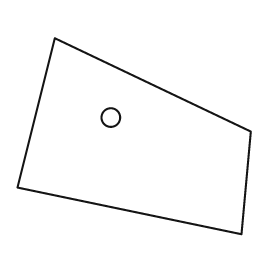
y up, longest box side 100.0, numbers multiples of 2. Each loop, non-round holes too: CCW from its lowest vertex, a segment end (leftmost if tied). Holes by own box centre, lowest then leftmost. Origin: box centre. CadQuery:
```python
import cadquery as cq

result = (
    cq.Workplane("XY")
    .moveTo(46.0, -42.0)
    .lineTo(50.0, 2.0)
    .lineTo(-34.0, 42.0)
    .lineTo(-50.0, -22.0)
    .close()
    .moveTo(-10.0, 8.0)
    .circle(4.0)
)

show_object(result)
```